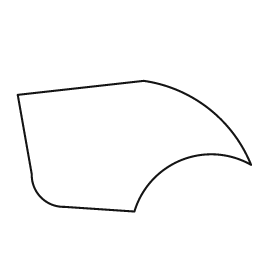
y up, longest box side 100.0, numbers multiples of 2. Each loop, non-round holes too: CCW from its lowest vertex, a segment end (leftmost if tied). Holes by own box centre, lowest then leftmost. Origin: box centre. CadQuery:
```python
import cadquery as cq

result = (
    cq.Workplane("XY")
    .moveTo(0.0, -28.0)
    .threePointArc((20.0, -6.0), (50.0, -8.0))
    .threePointArc((32.0, 16.0), (4.0, 28.0))
    .lineTo(-50.0, 22.0)
    .lineTo(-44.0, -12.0)
    .threePointArc((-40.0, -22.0), (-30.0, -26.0))
    .close()
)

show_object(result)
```